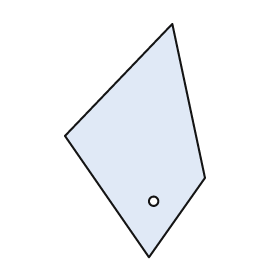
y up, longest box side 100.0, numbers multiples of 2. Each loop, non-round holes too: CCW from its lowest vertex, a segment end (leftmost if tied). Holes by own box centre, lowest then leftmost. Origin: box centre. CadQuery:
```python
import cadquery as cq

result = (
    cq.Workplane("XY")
    .moveTo(6.0, -50.0)
    .lineTo(30.0, -16.0)
    .lineTo(16.0, 50.0)
    .lineTo(-30.0, 2.0)
    .close()
    .moveTo(8.0, -26.0)
    .circle(2.0)
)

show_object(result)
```